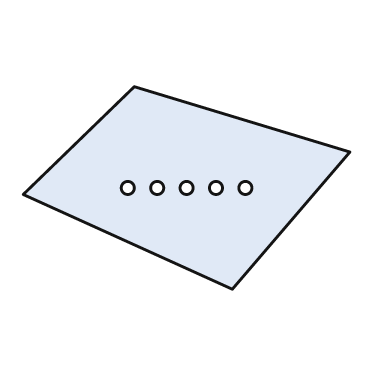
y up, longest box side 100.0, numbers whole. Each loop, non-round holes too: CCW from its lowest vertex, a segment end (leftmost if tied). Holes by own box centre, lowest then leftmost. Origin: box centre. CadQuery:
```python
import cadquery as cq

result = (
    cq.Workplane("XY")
    .moveTo(14.0, -31.0)
    .lineTo(50.0, 11.0)
    .lineTo(-16.0, 31.0)
    .lineTo(-50.0, -2.0)
    .close()
    .moveTo(-18.0, 0.0)
    .circle(2.0)
    .moveTo(-9.0, 0.0)
    .circle(2.0)
    .moveTo(0.0, 0.0)
    .circle(2.0)
    .moveTo(9.0, 0.0)
    .circle(2.0)
    .moveTo(18.0, 0.0)
    .circle(2.0)
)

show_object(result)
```